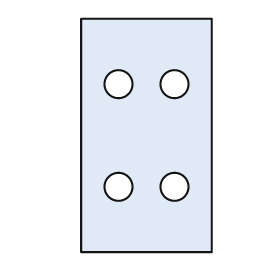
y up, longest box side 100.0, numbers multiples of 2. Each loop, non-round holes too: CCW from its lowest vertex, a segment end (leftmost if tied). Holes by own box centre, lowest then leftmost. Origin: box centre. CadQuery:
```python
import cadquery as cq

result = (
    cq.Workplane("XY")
    .moveTo(-28.0, -50.0)
    .lineTo(28.0, -50.0)
    .lineTo(28.0, 50.0)
    .lineTo(-28.0, 50.0)
    .close()
    .moveTo(-12.0, -22.0)
    .circle(6.0)
    .moveTo(12.0, -22.0)
    .circle(6.0)
    .moveTo(-12.0, 22.0)
    .circle(6.0)
    .moveTo(12.0, 22.0)
    .circle(6.0)
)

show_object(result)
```